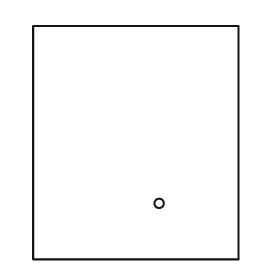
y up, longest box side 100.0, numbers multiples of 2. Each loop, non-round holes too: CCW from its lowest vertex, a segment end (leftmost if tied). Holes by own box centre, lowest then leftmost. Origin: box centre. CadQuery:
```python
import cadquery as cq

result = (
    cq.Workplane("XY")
    .moveTo(-44.0, -50.0)
    .lineTo(44.0, -50.0)
    .lineTo(44.0, 50.0)
    .lineTo(-44.0, 50.0)
    .close()
    .moveTo(10.0, -26.0)
    .circle(2.0)
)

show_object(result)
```